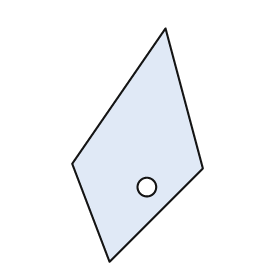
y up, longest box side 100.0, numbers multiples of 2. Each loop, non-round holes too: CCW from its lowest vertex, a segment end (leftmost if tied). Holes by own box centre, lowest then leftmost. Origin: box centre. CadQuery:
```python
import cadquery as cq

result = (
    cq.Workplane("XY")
    .moveTo(-12.0, -50.0)
    .lineTo(28.0, -10.0)
    .lineTo(12.0, 50.0)
    .lineTo(-28.0, -8.0)
    .close()
    .moveTo(4.0, -18.0)
    .circle(4.0)
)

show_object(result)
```